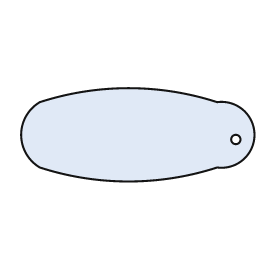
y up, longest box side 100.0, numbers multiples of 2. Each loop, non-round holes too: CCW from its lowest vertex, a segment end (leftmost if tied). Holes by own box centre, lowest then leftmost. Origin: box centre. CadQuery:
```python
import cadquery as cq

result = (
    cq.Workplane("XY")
    .moveTo(-42.0, -14.0)
    .threePointArc((-4.0, -20.0), (34.0, -14.0))
    .threePointArc((50.0, 0.0), (34.0, 14.0))
    .threePointArc((-4.0, 20.0), (-42.0, 14.0))
    .threePointArc((-50.0, 0.0), (-42.0, -14.0))
    .close()
    .moveTo(42.0, -2.0)
    .circle(2.0)
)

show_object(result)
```